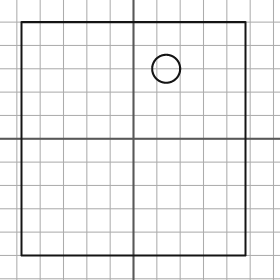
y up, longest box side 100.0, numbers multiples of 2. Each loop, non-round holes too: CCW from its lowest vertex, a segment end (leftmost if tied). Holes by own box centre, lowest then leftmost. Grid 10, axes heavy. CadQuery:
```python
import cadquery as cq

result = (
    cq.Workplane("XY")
    .moveTo(-48.0, -50.0)
    .lineTo(48.0, -50.0)
    .lineTo(48.0, 50.0)
    .lineTo(-48.0, 50.0)
    .close()
    .moveTo(14.0, 30.0)
    .circle(6.0)
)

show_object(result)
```